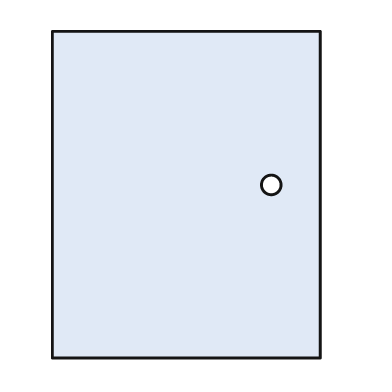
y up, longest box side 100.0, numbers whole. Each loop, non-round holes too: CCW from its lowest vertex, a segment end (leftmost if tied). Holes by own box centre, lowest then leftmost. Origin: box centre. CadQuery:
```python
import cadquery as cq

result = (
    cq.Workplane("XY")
    .moveTo(-41.0, -50.0)
    .lineTo(41.0, -50.0)
    .lineTo(41.0, 50.0)
    .lineTo(-41.0, 50.0)
    .close()
    .moveTo(26.0, 3.0)
    .circle(3.0)
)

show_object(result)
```